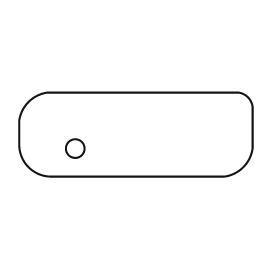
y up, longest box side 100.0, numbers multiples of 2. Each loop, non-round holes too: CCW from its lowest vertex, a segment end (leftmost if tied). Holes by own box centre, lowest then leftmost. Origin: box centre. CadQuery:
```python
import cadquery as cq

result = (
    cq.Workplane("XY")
    .moveTo(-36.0, -18.0)
    .lineTo(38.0, -18.0)
    .threePointArc((46.0, -14.0), (50.0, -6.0))
    .lineTo(50.0, 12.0)
    .threePointArc((48.0, 16.0), (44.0, 18.0))
    .lineTo(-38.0, 18.0)
    .threePointArc((-46.0, 14.0), (-50.0, 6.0))
    .lineTo(-50.0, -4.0)
    .threePointArc((-46.0, -14.0), (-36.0, -18.0))
    .close()
    .moveTo(-26.0, -6.0)
    .circle(4.0)
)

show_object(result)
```